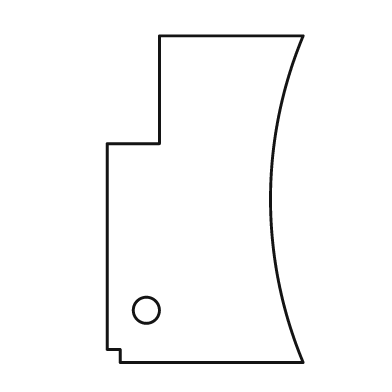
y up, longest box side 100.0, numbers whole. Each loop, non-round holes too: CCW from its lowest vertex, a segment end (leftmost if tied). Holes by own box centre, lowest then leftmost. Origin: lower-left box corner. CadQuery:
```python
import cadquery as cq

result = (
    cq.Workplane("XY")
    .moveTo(4.0, 0.0)
    .lineTo(60.0, 0.0)
    .threePointArc((50.0, 50.0), (60.0, 100.0))
    .lineTo(16.0, 100.0)
    .lineTo(16.0, 67.0)
    .lineTo(0.0, 67.0)
    .lineTo(0.0, 4.0)
    .lineTo(4.0, 4.0)
    .close()
    .moveTo(12.0, 16.0)
    .circle(4.0)
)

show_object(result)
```